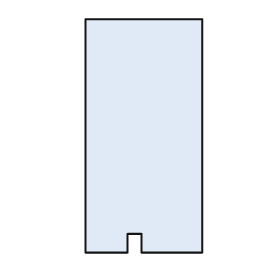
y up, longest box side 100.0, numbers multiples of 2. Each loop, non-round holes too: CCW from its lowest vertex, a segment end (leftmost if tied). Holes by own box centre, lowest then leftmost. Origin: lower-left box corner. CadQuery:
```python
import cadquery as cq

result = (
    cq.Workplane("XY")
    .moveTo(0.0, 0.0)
    .lineTo(18.0, 0.0)
    .lineTo(18.0, 8.0)
    .lineTo(24.0, 8.0)
    .lineTo(24.0, 0.0)
    .lineTo(50.0, 0.0)
    .lineTo(50.0, 100.0)
    .lineTo(0.0, 100.0)
    .close()
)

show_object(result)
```